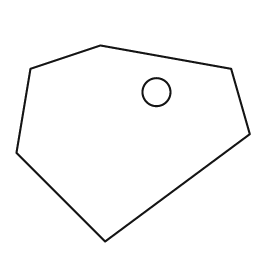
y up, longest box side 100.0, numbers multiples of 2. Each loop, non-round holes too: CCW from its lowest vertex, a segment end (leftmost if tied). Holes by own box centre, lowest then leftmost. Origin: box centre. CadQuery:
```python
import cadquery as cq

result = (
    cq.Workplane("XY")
    .moveTo(-12.0, -42.0)
    .lineTo(50.0, 4.0)
    .lineTo(42.0, 32.0)
    .lineTo(-14.0, 42.0)
    .lineTo(-44.0, 32.0)
    .lineTo(-50.0, -4.0)
    .close()
    .moveTo(10.0, 22.0)
    .circle(6.0)
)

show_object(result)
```